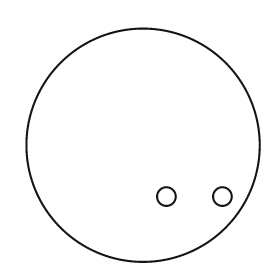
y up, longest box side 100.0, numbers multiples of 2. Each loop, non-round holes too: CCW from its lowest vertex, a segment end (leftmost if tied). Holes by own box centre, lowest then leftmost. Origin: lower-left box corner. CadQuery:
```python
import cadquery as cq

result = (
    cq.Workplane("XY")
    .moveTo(50.0, 50.0)
    .circle(50.0)
    .moveTo(60.0, 28.0)
    .circle(4.0)
    .moveTo(84.0, 28.0)
    .circle(4.0)
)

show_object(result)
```